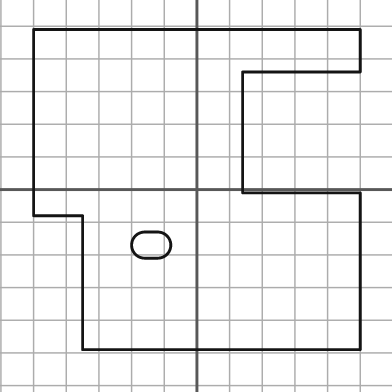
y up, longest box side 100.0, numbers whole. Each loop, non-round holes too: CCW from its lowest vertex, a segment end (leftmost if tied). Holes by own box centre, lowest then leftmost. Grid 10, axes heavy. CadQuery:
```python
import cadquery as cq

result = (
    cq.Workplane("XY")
    .moveTo(-35.0, -49.0)
    .lineTo(50.0, -49.0)
    .lineTo(50.0, -1.0)
    .lineTo(14.0, -1.0)
    .lineTo(14.0, 36.0)
    .lineTo(50.0, 36.0)
    .lineTo(50.0, 49.0)
    .lineTo(-50.0, 49.0)
    .lineTo(-50.0, -8.0)
    .lineTo(-35.0, -8.0)
    .close()
    .moveTo(-16.0, -21.0)
    .lineTo(-12.0, -21.0)
    .threePointArc((-8.0, -17.0), (-12.0, -13.0))
    .lineTo(-16.0, -13.0)
    .threePointArc((-20.0, -17.0), (-16.0, -21.0))
    .close()
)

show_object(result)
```